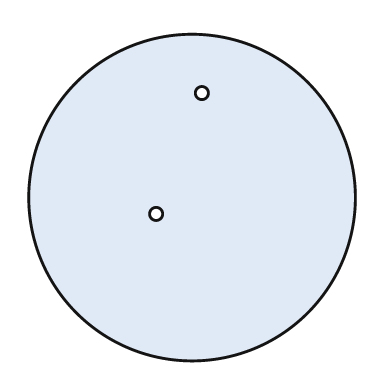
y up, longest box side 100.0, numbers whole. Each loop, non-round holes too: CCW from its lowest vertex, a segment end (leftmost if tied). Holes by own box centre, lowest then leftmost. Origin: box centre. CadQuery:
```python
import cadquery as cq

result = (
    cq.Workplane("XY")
    .moveTo(0.0, 0.0)
    .circle(50.0)
    .moveTo(-11.0, -5.0)
    .circle(2.0)
    .moveTo(3.0, 32.0)
    .circle(2.0)
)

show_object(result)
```